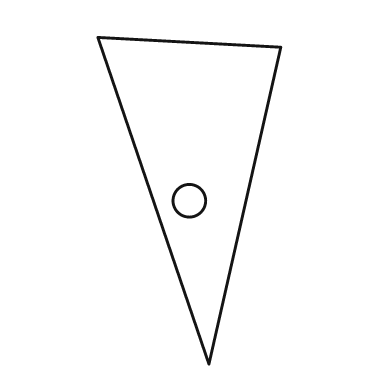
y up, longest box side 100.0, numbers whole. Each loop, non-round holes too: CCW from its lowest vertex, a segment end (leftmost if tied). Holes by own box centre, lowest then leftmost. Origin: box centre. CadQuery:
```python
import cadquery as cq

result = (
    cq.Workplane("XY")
    .moveTo(6.0, -50.0)
    .lineTo(28.0, 47.0)
    .lineTo(-28.0, 50.0)
    .close()
    .moveTo(0.0, 0.0)
    .circle(5.0)
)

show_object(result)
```